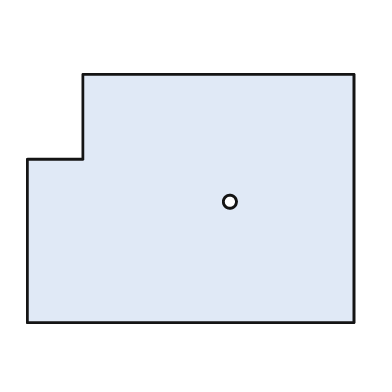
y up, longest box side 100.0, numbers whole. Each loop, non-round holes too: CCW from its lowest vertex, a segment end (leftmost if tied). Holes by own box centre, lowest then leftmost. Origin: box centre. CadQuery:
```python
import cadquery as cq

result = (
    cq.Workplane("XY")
    .moveTo(-50.0, -38.0)
    .lineTo(50.0, -38.0)
    .lineTo(50.0, 38.0)
    .lineTo(-33.0, 38.0)
    .lineTo(-33.0, 12.0)
    .lineTo(-50.0, 12.0)
    .close()
    .moveTo(12.0, -1.0)
    .circle(2.0)
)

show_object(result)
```